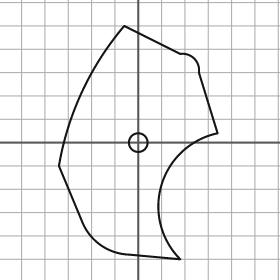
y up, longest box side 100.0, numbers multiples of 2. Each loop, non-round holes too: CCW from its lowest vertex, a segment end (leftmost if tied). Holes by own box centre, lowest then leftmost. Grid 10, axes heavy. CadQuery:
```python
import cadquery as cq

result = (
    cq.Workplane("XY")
    .moveTo(18.0, -50.0)
    .threePointArc((10.0, -18.0), (34.0, 4.0))
    .lineTo(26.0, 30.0)
    .threePointArc((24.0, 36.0), (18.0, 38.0))
    .lineTo(-6.0, 50.0)
    .threePointArc((-24.0, 22.0), (-34.0, -10.0))
    .lineTo(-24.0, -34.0)
    .threePointArc((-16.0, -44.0), (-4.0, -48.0))
    .close()
    .moveTo(0.0, 0.0)
    .circle(4.0)
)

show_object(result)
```